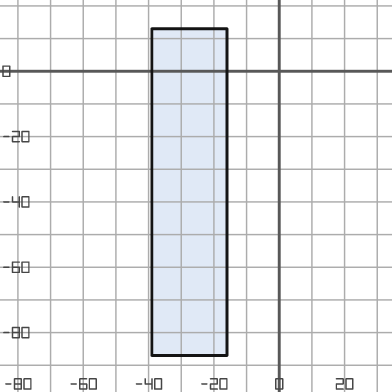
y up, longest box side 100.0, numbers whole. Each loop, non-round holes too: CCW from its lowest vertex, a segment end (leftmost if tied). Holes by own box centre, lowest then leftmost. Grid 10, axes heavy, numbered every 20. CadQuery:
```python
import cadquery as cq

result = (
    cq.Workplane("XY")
    .moveTo(-39.0, -87.0)
    .lineTo(-16.0, -87.0)
    .lineTo(-16.0, 13.0)
    .lineTo(-39.0, 13.0)
    .close()
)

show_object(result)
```